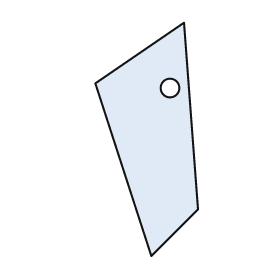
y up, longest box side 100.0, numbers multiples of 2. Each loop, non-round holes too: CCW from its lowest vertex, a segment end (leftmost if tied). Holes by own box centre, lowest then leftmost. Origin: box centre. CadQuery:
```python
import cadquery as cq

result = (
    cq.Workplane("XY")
    .moveTo(2.0, -50.0)
    .lineTo(22.0, -30.0)
    .lineTo(16.0, 50.0)
    .lineTo(-22.0, 24.0)
    .close()
    .moveTo(10.0, 22.0)
    .circle(4.0)
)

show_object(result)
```